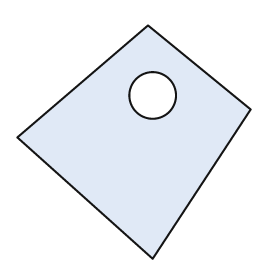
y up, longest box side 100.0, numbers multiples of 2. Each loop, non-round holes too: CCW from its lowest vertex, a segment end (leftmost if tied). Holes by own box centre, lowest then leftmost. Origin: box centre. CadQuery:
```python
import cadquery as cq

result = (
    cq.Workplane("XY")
    .moveTo(8.0, -50.0)
    .lineTo(50.0, 14.0)
    .lineTo(6.0, 50.0)
    .lineTo(-50.0, 2.0)
    .close()
    .moveTo(8.0, 20.0)
    .circle(10.0)
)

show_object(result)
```